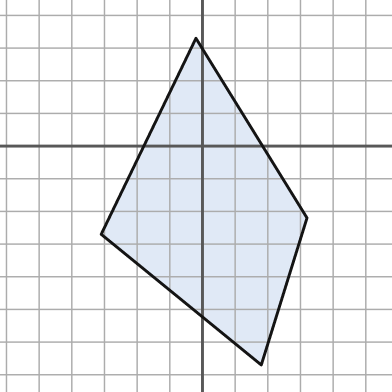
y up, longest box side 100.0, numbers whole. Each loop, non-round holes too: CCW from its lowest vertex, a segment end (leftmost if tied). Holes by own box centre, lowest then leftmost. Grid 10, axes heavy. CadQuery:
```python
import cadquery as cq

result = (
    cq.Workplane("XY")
    .moveTo(18.0, -67.0)
    .lineTo(32.0, -22.0)
    .lineTo(-2.0, 33.0)
    .lineTo(-31.0, -27.0)
    .close()
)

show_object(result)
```